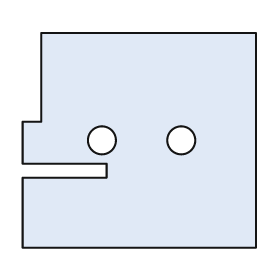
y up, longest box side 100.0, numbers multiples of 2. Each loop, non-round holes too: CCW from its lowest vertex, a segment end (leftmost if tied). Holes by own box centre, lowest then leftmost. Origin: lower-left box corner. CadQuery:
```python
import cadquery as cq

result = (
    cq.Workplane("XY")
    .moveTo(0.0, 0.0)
    .lineTo(100.0, 0.0)
    .lineTo(100.0, 92.0)
    .lineTo(8.0, 92.0)
    .lineTo(8.0, 54.0)
    .lineTo(0.0, 54.0)
    .lineTo(0.0, 36.0)
    .lineTo(36.0, 36.0)
    .lineTo(36.0, 30.0)
    .lineTo(0.0, 30.0)
    .close()
    .moveTo(34.0, 46.0)
    .circle(6.0)
    .moveTo(68.0, 46.0)
    .circle(6.0)
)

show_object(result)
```